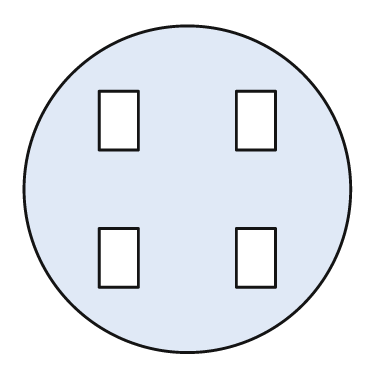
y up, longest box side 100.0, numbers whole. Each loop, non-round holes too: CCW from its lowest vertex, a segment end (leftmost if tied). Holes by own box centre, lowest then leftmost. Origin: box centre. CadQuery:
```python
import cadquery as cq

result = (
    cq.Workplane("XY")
    .moveTo(0.0, 0.0)
    .circle(50.0)
    .moveTo(-27.0, -30.0)
    .lineTo(-15.0, -30.0)
    .lineTo(-15.0, -12.0)
    .lineTo(-27.0, -12.0)
    .close()
    .moveTo(15.0, -30.0)
    .lineTo(27.0, -30.0)
    .lineTo(27.0, -12.0)
    .lineTo(15.0, -12.0)
    .close()
    .moveTo(-27.0, 12.0)
    .lineTo(-15.0, 12.0)
    .lineTo(-15.0, 30.0)
    .lineTo(-27.0, 30.0)
    .close()
    .moveTo(15.0, 12.0)
    .lineTo(27.0, 12.0)
    .lineTo(27.0, 30.0)
    .lineTo(15.0, 30.0)
    .close()
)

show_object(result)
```